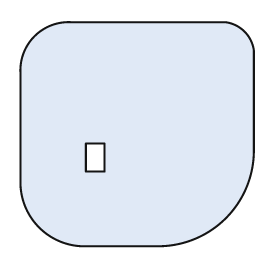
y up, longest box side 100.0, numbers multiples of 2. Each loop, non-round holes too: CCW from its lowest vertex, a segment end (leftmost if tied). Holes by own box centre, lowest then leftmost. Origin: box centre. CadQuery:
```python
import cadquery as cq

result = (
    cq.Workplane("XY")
    .moveTo(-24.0, -48.0)
    .lineTo(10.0, -48.0)
    .threePointArc((38.0, -36.0), (50.0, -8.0))
    .lineTo(50.0, 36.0)
    .threePointArc((46.0, 44.0), (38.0, 48.0))
    .lineTo(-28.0, 48.0)
    .threePointArc((-44.0, 42.0), (-50.0, 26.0))
    .lineTo(-50.0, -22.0)
    .threePointArc((-42.0, -40.0), (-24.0, -48.0))
    .close()
    .moveTo(-22.0, -16.0)
    .lineTo(-14.0, -16.0)
    .lineTo(-14.0, -4.0)
    .lineTo(-22.0, -4.0)
    .close()
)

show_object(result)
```